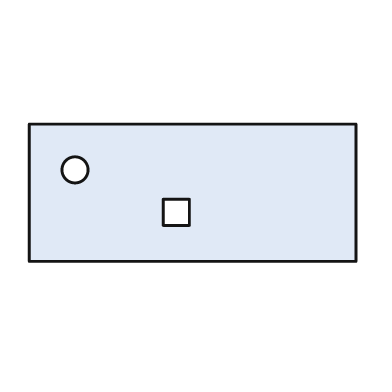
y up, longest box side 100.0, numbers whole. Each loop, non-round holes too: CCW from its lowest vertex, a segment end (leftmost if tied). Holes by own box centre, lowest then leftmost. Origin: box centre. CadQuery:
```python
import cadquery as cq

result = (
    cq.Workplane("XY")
    .moveTo(-50.0, -21.0)
    .lineTo(50.0, -21.0)
    .lineTo(50.0, 21.0)
    .lineTo(-50.0, 21.0)
    .close()
    .moveTo(-9.0, -10.0)
    .lineTo(-1.0, -10.0)
    .lineTo(-1.0, -2.0)
    .lineTo(-9.0, -2.0)
    .close()
    .moveTo(-36.0, 7.0)
    .circle(4.0)
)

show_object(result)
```